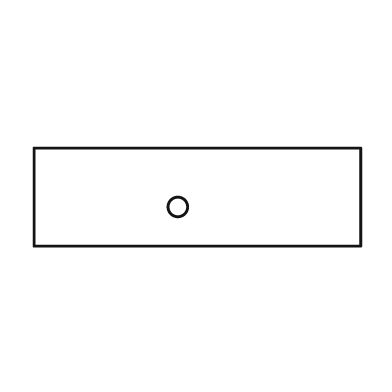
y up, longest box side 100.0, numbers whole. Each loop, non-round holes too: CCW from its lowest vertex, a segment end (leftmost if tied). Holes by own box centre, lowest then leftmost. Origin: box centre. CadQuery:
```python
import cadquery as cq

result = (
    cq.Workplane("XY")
    .moveTo(-50.0, -15.0)
    .lineTo(50.0, -15.0)
    .lineTo(50.0, 15.0)
    .lineTo(-50.0, 15.0)
    .close()
    .moveTo(-6.0, -3.0)
    .circle(3.0)
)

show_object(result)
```